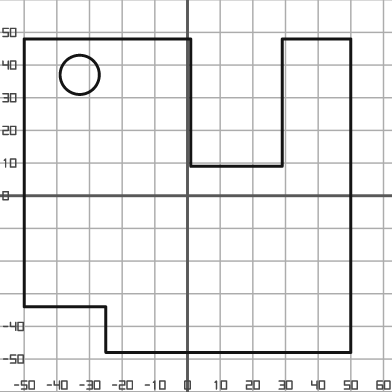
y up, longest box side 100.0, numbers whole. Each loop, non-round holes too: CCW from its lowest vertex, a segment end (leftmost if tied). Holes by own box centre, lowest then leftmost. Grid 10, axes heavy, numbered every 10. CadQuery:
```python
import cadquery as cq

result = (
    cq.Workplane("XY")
    .moveTo(-25.0, -48.0)
    .lineTo(50.0, -48.0)
    .lineTo(50.0, 48.0)
    .lineTo(29.0, 48.0)
    .lineTo(29.0, 9.0)
    .lineTo(1.0, 9.0)
    .lineTo(1.0, 48.0)
    .lineTo(-50.0, 48.0)
    .lineTo(-50.0, -34.0)
    .lineTo(-25.0, -34.0)
    .close()
    .moveTo(-33.0, 37.0)
    .circle(6.0)
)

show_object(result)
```